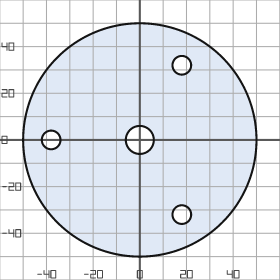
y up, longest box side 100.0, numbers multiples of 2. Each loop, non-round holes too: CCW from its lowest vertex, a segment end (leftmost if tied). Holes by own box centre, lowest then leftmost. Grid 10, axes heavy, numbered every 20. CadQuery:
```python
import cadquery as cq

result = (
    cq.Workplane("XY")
    .moveTo(0.0, 0.0)
    .circle(50.0)
    .moveTo(18.0, -32.0)
    .circle(4.0)
    .moveTo(-38.0, 0.0)
    .circle(4.0)
    .moveTo(0.0, 0.0)
    .circle(6.0)
    .moveTo(18.0, 32.0)
    .circle(4.0)
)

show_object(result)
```